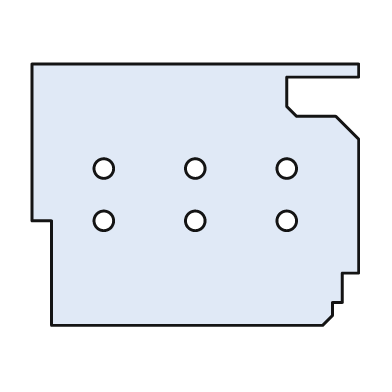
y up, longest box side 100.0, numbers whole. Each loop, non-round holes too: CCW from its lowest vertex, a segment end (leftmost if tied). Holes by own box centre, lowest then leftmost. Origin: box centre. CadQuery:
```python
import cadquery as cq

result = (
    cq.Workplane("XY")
    .moveTo(-44.0, -40.0)
    .lineTo(39.0, -40.0)
    .lineTo(42.0, -37.0)
    .lineTo(42.0, -33.0)
    .lineTo(45.0, -33.0)
    .lineTo(45.0, -24.0)
    .lineTo(50.0, -24.0)
    .lineTo(50.0, 17.0)
    .lineTo(43.0, 24.0)
    .lineTo(31.0, 24.0)
    .lineTo(28.0, 27.0)
    .lineTo(28.0, 36.0)
    .lineTo(50.0, 36.0)
    .lineTo(50.0, 40.0)
    .lineTo(-50.0, 40.0)
    .lineTo(-50.0, -8.0)
    .lineTo(-44.0, -8.0)
    .close()
    .moveTo(-28.0, -8.0)
    .circle(3.0)
    .moveTo(0.0, -8.0)
    .circle(3.0)
    .moveTo(28.0, -8.0)
    .circle(3.0)
    .moveTo(-28.0, 8.0)
    .circle(3.0)
    .moveTo(0.0, 8.0)
    .circle(3.0)
    .moveTo(28.0, 8.0)
    .circle(3.0)
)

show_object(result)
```